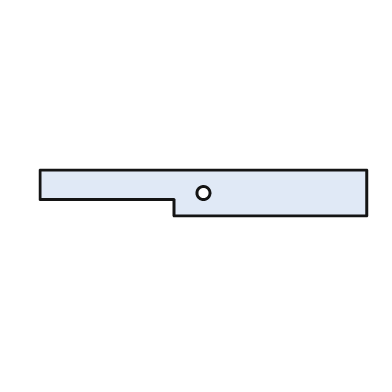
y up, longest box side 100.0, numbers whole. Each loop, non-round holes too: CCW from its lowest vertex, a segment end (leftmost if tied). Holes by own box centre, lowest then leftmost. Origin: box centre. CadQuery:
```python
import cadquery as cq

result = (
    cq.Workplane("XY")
    .moveTo(-9.0, -7.0)
    .lineTo(50.0, -7.0)
    .lineTo(50.0, 7.0)
    .lineTo(-50.0, 7.0)
    .lineTo(-50.0, -2.0)
    .lineTo(-9.0, -2.0)
    .close()
    .moveTo(0.0, 0.0)
    .circle(2.0)
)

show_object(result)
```